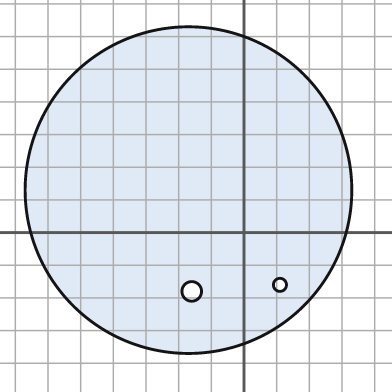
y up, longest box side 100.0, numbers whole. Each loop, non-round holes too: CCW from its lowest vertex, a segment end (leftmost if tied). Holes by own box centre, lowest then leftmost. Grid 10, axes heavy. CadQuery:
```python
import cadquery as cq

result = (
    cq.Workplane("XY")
    .moveTo(-17.0, 13.0)
    .circle(50.0)
    .moveTo(-16.0, -18.0)
    .circle(3.0)
    .moveTo(11.0, -16.0)
    .circle(2.0)
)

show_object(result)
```